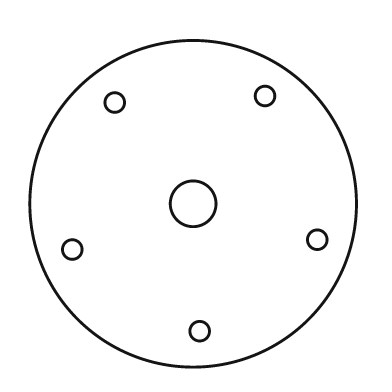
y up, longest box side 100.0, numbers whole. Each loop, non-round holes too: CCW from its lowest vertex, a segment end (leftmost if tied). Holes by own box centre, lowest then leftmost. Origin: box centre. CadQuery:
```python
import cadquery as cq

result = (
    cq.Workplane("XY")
    .moveTo(0.0, 0.0)
    .circle(50.0)
    .moveTo(2.0, -39.0)
    .circle(3.0)
    .moveTo(-37.0, -14.0)
    .circle(3.0)
    .moveTo(38.0, -11.0)
    .circle(3.0)
    .moveTo(0.0, 0.0)
    .circle(7.0)
    .moveTo(-24.0, 31.0)
    .circle(3.0)
    .moveTo(22.0, 33.0)
    .circle(3.0)
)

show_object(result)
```